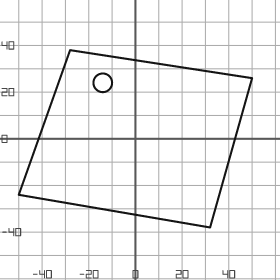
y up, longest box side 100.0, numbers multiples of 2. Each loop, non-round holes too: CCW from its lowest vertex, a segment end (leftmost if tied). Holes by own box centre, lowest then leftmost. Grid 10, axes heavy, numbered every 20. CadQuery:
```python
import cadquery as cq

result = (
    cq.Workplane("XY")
    .moveTo(32.0, -38.0)
    .lineTo(50.0, 26.0)
    .lineTo(-28.0, 38.0)
    .lineTo(-50.0, -24.0)
    .close()
    .moveTo(-14.0, 24.0)
    .circle(4.0)
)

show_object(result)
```